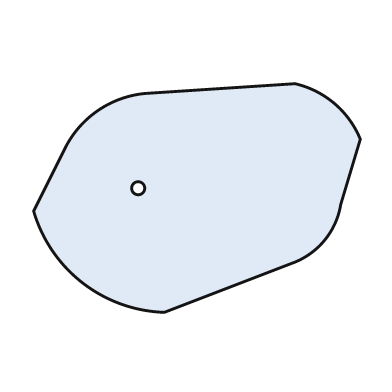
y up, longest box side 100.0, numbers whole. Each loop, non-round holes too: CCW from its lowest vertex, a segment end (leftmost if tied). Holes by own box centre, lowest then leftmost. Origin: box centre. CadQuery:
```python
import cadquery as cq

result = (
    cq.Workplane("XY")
    .moveTo(-10.0, -35.0)
    .lineTo(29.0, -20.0)
    .threePointArc((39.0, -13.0), (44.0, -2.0))
    .lineTo(50.0, 18.0)
    .threePointArc((42.0, 29.0), (30.0, 35.0))
    .lineTo(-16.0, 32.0)
    .threePointArc((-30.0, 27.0), (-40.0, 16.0))
    .lineTo(-50.0, -4.0)
    .threePointArc((-35.0, -26.0), (-10.0, -35.0))
    .close()
    .moveTo(-18.0, 3.0)
    .circle(2.0)
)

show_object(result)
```